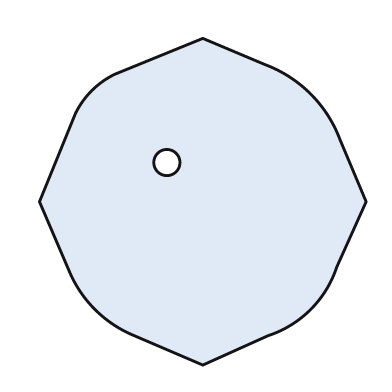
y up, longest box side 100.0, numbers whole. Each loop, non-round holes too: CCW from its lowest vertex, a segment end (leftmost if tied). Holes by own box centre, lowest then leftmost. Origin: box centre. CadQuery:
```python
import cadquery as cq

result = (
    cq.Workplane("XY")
    .moveTo(0.0, -50.0)
    .lineTo(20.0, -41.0)
    .threePointArc((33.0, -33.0), (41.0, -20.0))
    .lineTo(50.0, 0.0)
    .lineTo(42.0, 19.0)
    .threePointArc((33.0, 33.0), (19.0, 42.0))
    .lineTo(0.0, 50.0)
    .lineTo(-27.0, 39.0)
    .threePointArc((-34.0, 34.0), (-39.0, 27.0))
    .lineTo(-50.0, 0.0)
    .lineTo(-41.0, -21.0)
    .threePointArc((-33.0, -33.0), (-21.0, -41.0))
    .close()
    .moveTo(-11.0, 12.0)
    .circle(4.0)
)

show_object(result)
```